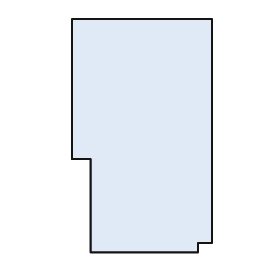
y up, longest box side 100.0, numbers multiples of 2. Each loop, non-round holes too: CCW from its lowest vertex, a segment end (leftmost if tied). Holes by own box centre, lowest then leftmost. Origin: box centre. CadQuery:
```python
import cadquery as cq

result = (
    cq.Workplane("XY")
    .moveTo(-22.0, -50.0)
    .lineTo(24.0, -50.0)
    .lineTo(24.0, -46.0)
    .lineTo(30.0, -46.0)
    .lineTo(30.0, 50.0)
    .lineTo(-30.0, 50.0)
    .lineTo(-30.0, -10.0)
    .lineTo(-22.0, -10.0)
    .close()
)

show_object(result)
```